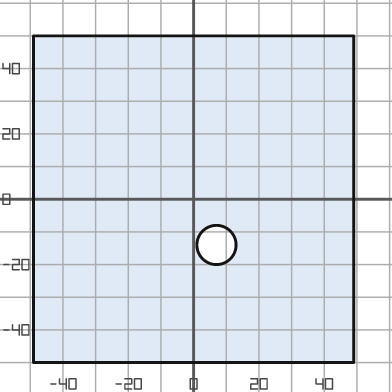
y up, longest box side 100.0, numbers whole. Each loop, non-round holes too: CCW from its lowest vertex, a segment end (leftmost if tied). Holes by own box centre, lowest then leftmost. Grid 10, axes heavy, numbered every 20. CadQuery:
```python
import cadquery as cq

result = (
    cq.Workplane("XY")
    .moveTo(-49.0, -50.0)
    .lineTo(49.0, -50.0)
    .lineTo(49.0, 50.0)
    .lineTo(-49.0, 50.0)
    .close()
    .moveTo(7.0, -14.0)
    .circle(6.0)
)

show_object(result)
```